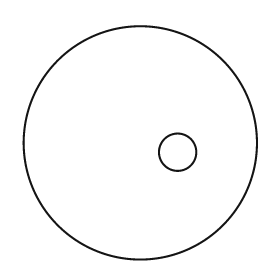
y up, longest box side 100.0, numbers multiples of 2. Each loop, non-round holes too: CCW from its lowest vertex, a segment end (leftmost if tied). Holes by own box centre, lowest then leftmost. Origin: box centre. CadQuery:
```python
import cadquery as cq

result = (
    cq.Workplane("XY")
    .moveTo(0.0, 0.0)
    .circle(50.0)
    .moveTo(16.0, -4.0)
    .circle(8.0)
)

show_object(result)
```